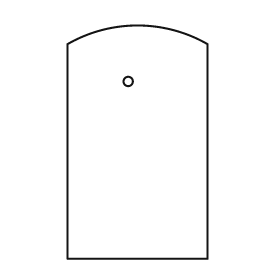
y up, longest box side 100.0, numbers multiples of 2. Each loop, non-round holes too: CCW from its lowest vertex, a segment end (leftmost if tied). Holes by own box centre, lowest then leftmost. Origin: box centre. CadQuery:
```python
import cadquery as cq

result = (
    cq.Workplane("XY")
    .moveTo(-30.0, -50.0)
    .lineTo(30.0, -50.0)
    .lineTo(30.0, 42.0)
    .threePointArc((0.0, 50.0), (-30.0, 42.0))
    .close()
    .moveTo(-4.0, 26.0)
    .circle(2.0)
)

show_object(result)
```